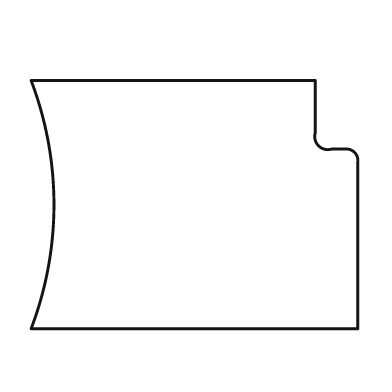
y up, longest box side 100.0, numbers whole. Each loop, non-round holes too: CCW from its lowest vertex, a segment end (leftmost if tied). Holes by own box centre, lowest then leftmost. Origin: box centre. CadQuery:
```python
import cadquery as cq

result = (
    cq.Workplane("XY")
    .moveTo(-50.0, -38.0)
    .lineTo(50.0, -38.0)
    .lineTo(50.0, 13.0)
    .threePointArc((49.0, 16.0), (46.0, 17.0))
    .lineTo(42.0, 17.0)
    .threePointArc((38.0, 18.0), (37.0, 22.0))
    .lineTo(37.0, 38.0)
    .lineTo(-50.0, 38.0)
    .threePointArc((-43.0, 0.0), (-50.0, -38.0))
    .close()
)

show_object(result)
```